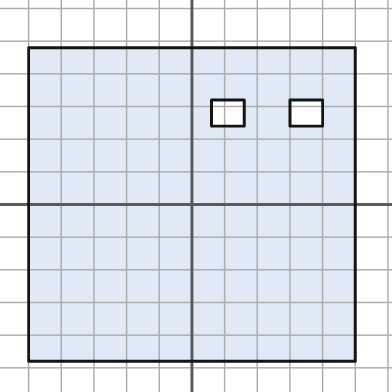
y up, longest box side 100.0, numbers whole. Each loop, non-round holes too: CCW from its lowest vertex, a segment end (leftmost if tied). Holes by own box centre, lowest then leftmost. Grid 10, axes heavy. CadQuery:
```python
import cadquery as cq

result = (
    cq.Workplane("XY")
    .moveTo(-50.0, -48.0)
    .lineTo(50.0, -48.0)
    .lineTo(50.0, 48.0)
    .lineTo(-50.0, 48.0)
    .close()
    .moveTo(6.0, 24.0)
    .lineTo(16.0, 24.0)
    .lineTo(16.0, 32.0)
    .lineTo(6.0, 32.0)
    .close()
    .moveTo(30.0, 24.0)
    .lineTo(40.0, 24.0)
    .lineTo(40.0, 32.0)
    .lineTo(30.0, 32.0)
    .close()
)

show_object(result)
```